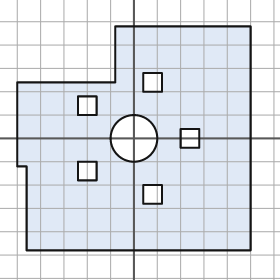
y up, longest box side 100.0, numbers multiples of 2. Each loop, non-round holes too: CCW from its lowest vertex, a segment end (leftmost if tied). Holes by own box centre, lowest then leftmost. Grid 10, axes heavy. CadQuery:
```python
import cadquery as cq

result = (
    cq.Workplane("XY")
    .moveTo(-46.0, -48.0)
    .lineTo(50.0, -48.0)
    .lineTo(50.0, 48.0)
    .lineTo(-8.0, 48.0)
    .lineTo(-8.0, 24.0)
    .lineTo(-50.0, 24.0)
    .lineTo(-50.0, -12.0)
    .lineTo(-46.0, -12.0)
    .close()
    .moveTo(4.0, -28.0)
    .lineTo(12.0, -28.0)
    .lineTo(12.0, -20.0)
    .lineTo(4.0, -20.0)
    .close()
    .moveTo(-24.0, -18.0)
    .lineTo(-16.0, -18.0)
    .lineTo(-16.0, -10.0)
    .lineTo(-24.0, -10.0)
    .close()
    .moveTo(0.0, 0.0)
    .circle(10.0)
    .moveTo(20.0, -4.0)
    .lineTo(28.0, -4.0)
    .lineTo(28.0, 4.0)
    .lineTo(20.0, 4.0)
    .close()
    .moveTo(-24.0, 10.0)
    .lineTo(-16.0, 10.0)
    .lineTo(-16.0, 18.0)
    .lineTo(-24.0, 18.0)
    .close()
    .moveTo(4.0, 20.0)
    .lineTo(12.0, 20.0)
    .lineTo(12.0, 28.0)
    .lineTo(4.0, 28.0)
    .close()
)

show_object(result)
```